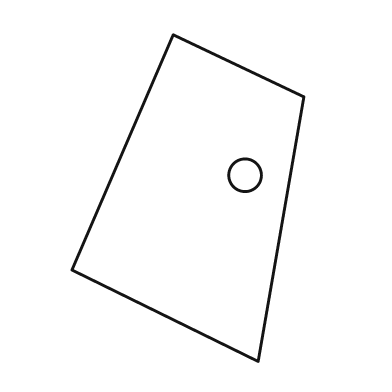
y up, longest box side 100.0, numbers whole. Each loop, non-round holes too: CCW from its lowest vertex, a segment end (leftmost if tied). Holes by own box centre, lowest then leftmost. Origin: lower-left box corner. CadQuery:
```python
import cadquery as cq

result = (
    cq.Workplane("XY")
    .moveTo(57.0, 0.0)
    .lineTo(71.0, 81.0)
    .lineTo(31.0, 100.0)
    .lineTo(0.0, 28.0)
    .close()
    .moveTo(53.0, 57.0)
    .circle(5.0)
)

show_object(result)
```